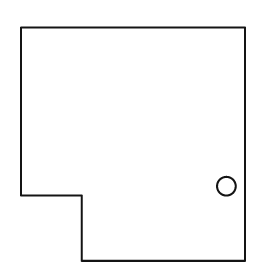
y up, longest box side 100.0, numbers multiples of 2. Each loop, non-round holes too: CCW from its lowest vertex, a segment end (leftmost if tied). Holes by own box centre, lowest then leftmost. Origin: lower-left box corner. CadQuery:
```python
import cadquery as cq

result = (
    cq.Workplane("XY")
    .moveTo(26.0, 0.0)
    .lineTo(96.0, 0.0)
    .lineTo(96.0, 100.0)
    .lineTo(0.0, 100.0)
    .lineTo(0.0, 28.0)
    .lineTo(26.0, 28.0)
    .close()
    .moveTo(88.0, 32.0)
    .circle(4.0)
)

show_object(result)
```